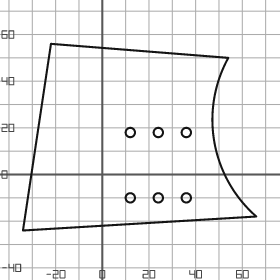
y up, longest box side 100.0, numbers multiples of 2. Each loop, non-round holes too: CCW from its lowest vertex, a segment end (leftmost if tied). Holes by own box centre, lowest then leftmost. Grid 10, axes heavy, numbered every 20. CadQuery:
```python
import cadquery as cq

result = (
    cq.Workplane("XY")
    .moveTo(-34.0, -24.0)
    .lineTo(66.0, -18.0)
    .threePointArc((48.0, 14.0), (54.0, 50.0))
    .lineTo(-22.0, 56.0)
    .close()
    .moveTo(12.0, -10.0)
    .circle(2.0)
    .moveTo(24.0, -10.0)
    .circle(2.0)
    .moveTo(36.0, -10.0)
    .circle(2.0)
    .moveTo(12.0, 18.0)
    .circle(2.0)
    .moveTo(24.0, 18.0)
    .circle(2.0)
    .moveTo(36.0, 18.0)
    .circle(2.0)
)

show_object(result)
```